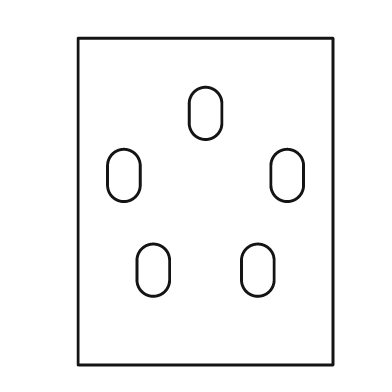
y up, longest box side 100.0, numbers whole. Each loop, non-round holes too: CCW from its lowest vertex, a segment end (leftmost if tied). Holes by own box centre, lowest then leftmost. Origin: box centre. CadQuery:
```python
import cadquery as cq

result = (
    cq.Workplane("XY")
    .moveTo(-39.0, -50.0)
    .lineTo(39.0, -50.0)
    .lineTo(39.0, 50.0)
    .lineTo(-39.0, 50.0)
    .close()
    .moveTo(-21.0, -24.0)
    .threePointArc((-16.0, -29.0), (-11.0, -24.0))
    .lineTo(-11.0, -18.0)
    .threePointArc((-16.0, -13.0), (-21.0, -18.0))
    .close()
    .moveTo(11.0, -24.0)
    .threePointArc((16.0, -29.0), (21.0, -24.0))
    .lineTo(21.0, -18.0)
    .threePointArc((16.0, -13.0), (11.0, -18.0))
    .close()
    .moveTo(-30.0, 5.0)
    .threePointArc((-25.0, 0.0), (-20.0, 5.0))
    .lineTo(-20.0, 11.0)
    .threePointArc((-25.0, 16.0), (-30.0, 11.0))
    .close()
    .moveTo(20.0, 5.0)
    .threePointArc((25.0, 0.0), (30.0, 5.0))
    .lineTo(30.0, 11.0)
    .threePointArc((25.0, 16.0), (20.0, 11.0))
    .close()
    .moveTo(-5.0, 24.0)
    .threePointArc((0.0, 19.0), (5.0, 24.0))
    .lineTo(5.0, 30.0)
    .threePointArc((0.0, 35.0), (-5.0, 30.0))
    .close()
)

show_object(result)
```